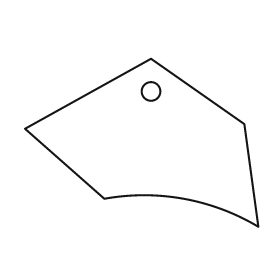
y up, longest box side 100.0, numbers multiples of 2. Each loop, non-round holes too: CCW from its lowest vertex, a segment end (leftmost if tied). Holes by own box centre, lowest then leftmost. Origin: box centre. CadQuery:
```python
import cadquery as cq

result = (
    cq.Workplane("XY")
    .moveTo(50.0, -36.0)
    .lineTo(44.0, 8.0)
    .lineTo(4.0, 36.0)
    .lineTo(-50.0, 6.0)
    .lineTo(-16.0, -24.0)
    .threePointArc((18.0, -24.0), (50.0, -36.0))
    .close()
    .moveTo(4.0, 22.0)
    .circle(4.0)
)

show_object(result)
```